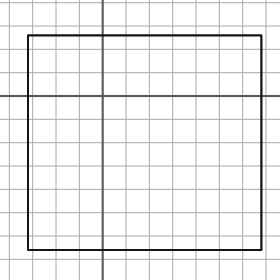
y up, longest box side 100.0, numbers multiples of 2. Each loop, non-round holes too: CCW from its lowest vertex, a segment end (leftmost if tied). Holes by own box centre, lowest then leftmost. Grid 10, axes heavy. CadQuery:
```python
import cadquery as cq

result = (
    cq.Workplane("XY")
    .moveTo(-32.0, -66.0)
    .lineTo(68.0, -66.0)
    .lineTo(68.0, 26.0)
    .lineTo(-32.0, 26.0)
    .close()
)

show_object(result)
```